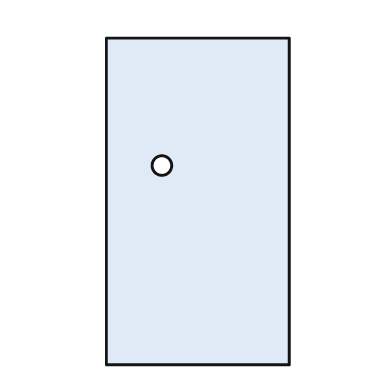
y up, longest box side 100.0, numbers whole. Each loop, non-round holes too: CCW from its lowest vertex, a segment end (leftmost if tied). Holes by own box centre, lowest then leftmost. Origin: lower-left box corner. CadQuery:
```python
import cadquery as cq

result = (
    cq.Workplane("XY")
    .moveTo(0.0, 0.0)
    .lineTo(56.0, 0.0)
    .lineTo(56.0, 100.0)
    .lineTo(0.0, 100.0)
    .close()
    .moveTo(17.0, 61.0)
    .circle(3.0)
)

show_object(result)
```